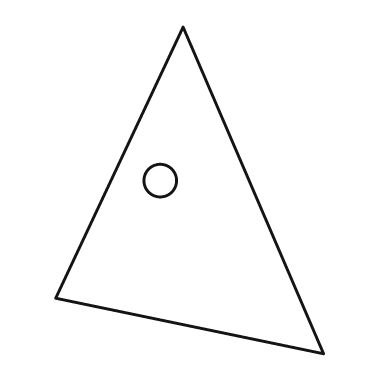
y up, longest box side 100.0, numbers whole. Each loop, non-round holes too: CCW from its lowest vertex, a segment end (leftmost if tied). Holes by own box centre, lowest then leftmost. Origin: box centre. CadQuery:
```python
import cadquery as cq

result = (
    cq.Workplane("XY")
    .moveTo(41.0, -50.0)
    .lineTo(-2.0, 50.0)
    .lineTo(-41.0, -33.0)
    .close()
    .moveTo(-9.0, 3.0)
    .circle(5.0)
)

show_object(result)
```